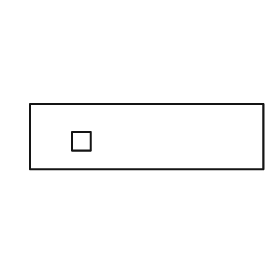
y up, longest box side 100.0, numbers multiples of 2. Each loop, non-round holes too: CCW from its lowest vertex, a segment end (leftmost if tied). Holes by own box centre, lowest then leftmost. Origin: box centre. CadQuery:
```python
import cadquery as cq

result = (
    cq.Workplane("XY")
    .moveTo(-50.0, -14.0)
    .lineTo(50.0, -14.0)
    .lineTo(50.0, 14.0)
    .lineTo(-50.0, 14.0)
    .close()
    .moveTo(-32.0, -6.0)
    .lineTo(-24.0, -6.0)
    .lineTo(-24.0, 2.0)
    .lineTo(-32.0, 2.0)
    .close()
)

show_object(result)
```